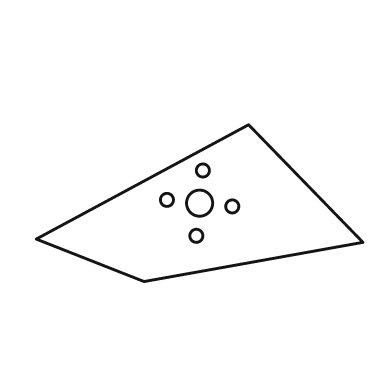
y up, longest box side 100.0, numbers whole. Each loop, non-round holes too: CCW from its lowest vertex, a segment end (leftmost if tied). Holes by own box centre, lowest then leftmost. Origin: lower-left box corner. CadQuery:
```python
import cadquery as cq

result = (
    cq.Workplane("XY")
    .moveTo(33.0, 0.0)
    .lineTo(100.0, 12.0)
    .lineTo(65.0, 48.0)
    .lineTo(0.0, 13.0)
    .close()
    .moveTo(49.0, 14.0)
    .circle(2.0)
    .moveTo(60.0, 23.0)
    .circle(2.0)
    .moveTo(50.0, 24.0)
    .circle(4.0)
    .moveTo(40.0, 25.0)
    .circle(2.0)
    .moveTo(51.0, 34.0)
    .circle(2.0)
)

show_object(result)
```